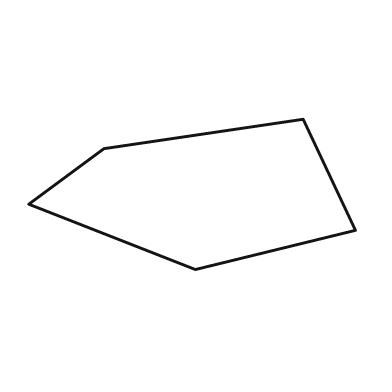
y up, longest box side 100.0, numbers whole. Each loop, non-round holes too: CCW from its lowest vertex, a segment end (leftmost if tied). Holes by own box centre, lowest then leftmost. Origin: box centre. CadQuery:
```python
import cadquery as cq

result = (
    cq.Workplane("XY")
    .moveTo(1.0, -23.0)
    .lineTo(50.0, -11.0)
    .lineTo(34.0, 23.0)
    .lineTo(-27.0, 14.0)
    .lineTo(-50.0, -3.0)
    .close()
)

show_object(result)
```